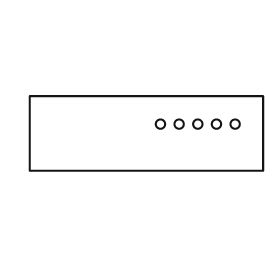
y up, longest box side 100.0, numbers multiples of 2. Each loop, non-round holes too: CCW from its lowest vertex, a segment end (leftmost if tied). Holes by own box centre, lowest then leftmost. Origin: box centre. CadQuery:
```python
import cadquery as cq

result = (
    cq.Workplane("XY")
    .moveTo(-50.0, -16.0)
    .lineTo(50.0, -16.0)
    .lineTo(50.0, 16.0)
    .lineTo(-50.0, 16.0)
    .close()
    .moveTo(6.0, 4.0)
    .circle(2.0)
    .moveTo(14.0, 4.0)
    .circle(2.0)
    .moveTo(22.0, 4.0)
    .circle(2.0)
    .moveTo(30.0, 4.0)
    .circle(2.0)
    .moveTo(38.0, 4.0)
    .circle(2.0)
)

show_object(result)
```